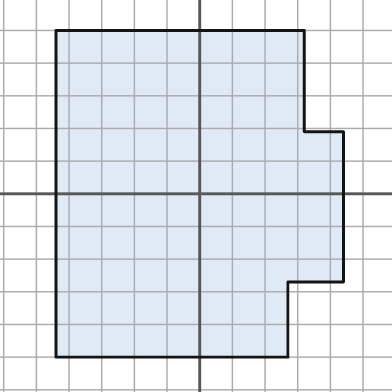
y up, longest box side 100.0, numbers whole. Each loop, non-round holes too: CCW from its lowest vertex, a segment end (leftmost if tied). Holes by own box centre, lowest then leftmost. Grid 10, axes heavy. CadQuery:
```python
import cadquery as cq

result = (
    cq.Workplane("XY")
    .moveTo(-44.0, -50.0)
    .lineTo(27.0, -50.0)
    .lineTo(27.0, -27.0)
    .lineTo(44.0, -27.0)
    .lineTo(44.0, 19.0)
    .lineTo(32.0, 19.0)
    .lineTo(32.0, 50.0)
    .lineTo(-44.0, 50.0)
    .close()
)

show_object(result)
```